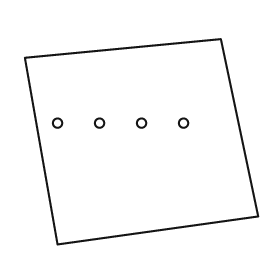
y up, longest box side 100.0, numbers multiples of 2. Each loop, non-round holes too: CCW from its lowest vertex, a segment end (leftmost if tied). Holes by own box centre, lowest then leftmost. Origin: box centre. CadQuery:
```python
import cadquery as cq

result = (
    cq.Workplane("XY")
    .moveTo(-36.0, -44.0)
    .lineTo(50.0, -32.0)
    .lineTo(34.0, 44.0)
    .lineTo(-50.0, 36.0)
    .close()
    .moveTo(-36.0, 8.0)
    .circle(2.0)
    .moveTo(-18.0, 8.0)
    .circle(2.0)
    .moveTo(0.0, 8.0)
    .circle(2.0)
    .moveTo(18.0, 8.0)
    .circle(2.0)
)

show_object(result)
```